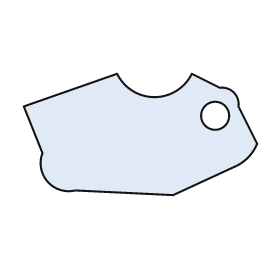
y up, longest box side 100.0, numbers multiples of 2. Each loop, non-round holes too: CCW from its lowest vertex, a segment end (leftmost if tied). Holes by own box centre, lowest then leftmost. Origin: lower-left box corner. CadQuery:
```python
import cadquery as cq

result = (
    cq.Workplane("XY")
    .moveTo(64.0, 0.0)
    .lineTo(90.0, 12.0)
    .threePointArc((96.0, 16.0), (100.0, 22.0))
    .lineTo(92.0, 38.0)
    .threePointArc((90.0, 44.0), (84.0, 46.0))
    .lineTo(72.0, 52.0)
    .threePointArc((56.0, 42.0), (40.0, 52.0))
    .lineTo(0.0, 38.0)
    .lineTo(8.0, 18.0)
    .threePointArc((10.0, 6.0), (22.0, 2.0))
    .close()
    .moveTo(82.0, 34.0)
    .circle(6.0)
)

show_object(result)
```